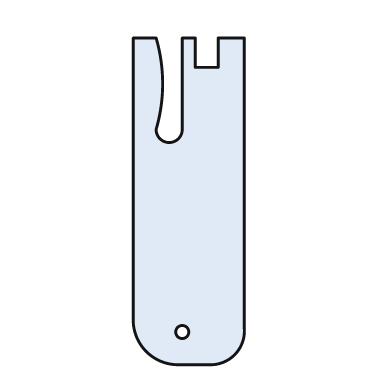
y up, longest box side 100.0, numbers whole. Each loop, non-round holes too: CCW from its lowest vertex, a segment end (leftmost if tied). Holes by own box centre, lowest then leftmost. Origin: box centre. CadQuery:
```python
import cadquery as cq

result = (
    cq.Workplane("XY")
    .moveTo(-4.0, -50.0)
    .lineTo(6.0, -50.0)
    .threePointArc((14.0, -47.0), (17.0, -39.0))
    .lineTo(17.0, 50.0)
    .lineTo(9.0, 50.0)
    .lineTo(9.0, 41.0)
    .lineTo(2.0, 41.0)
    .lineTo(2.0, 50.0)
    .lineTo(-2.0, 50.0)
    .lineTo(-2.0, 22.0)
    .threePointArc((-6.0, 18.0), (-10.0, 22.0))
    .threePointArc((-8.0, 36.0), (-10.0, 50.0))
    .lineTo(-17.0, 50.0)
    .lineTo(-17.0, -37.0)
    .threePointArc((-13.0, -46.0), (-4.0, -50.0))
    .close()
    .moveTo(-2.0, -40.0)
    .circle(2.0)
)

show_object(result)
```